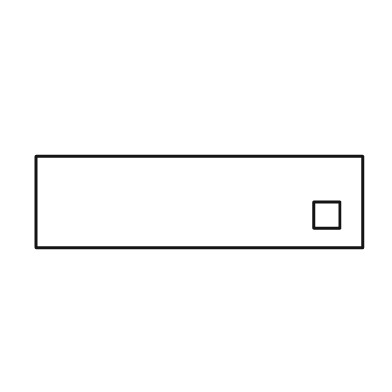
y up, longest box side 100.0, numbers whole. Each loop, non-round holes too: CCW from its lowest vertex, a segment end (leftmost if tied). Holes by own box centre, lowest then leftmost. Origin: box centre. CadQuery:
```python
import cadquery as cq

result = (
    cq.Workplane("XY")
    .moveTo(-50.0, -14.0)
    .lineTo(50.0, -14.0)
    .lineTo(50.0, 14.0)
    .lineTo(-50.0, 14.0)
    .close()
    .moveTo(35.0, -8.0)
    .lineTo(43.0, -8.0)
    .lineTo(43.0, 0.0)
    .lineTo(35.0, 0.0)
    .close()
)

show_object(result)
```